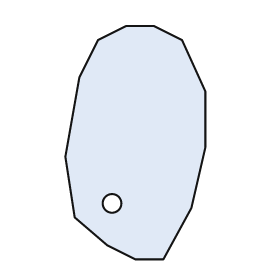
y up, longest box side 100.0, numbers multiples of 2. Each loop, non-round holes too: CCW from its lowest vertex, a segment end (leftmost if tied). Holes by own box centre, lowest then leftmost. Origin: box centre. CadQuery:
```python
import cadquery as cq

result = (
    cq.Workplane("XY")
    .moveTo(0.0, -50.0)
    .lineTo(12.0, -50.0)
    .lineTo(24.0, -28.0)
    .lineTo(30.0, -2.0)
    .lineTo(30.0, 22.0)
    .lineTo(20.0, 44.0)
    .lineTo(8.0, 50.0)
    .lineTo(-4.0, 50.0)
    .lineTo(-16.0, 44.0)
    .lineTo(-24.0, 28.0)
    .lineTo(-30.0, -6.0)
    .lineTo(-26.0, -32.0)
    .lineTo(-12.0, -44.0)
    .close()
    .moveTo(-10.0, -26.0)
    .circle(4.0)
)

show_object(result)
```